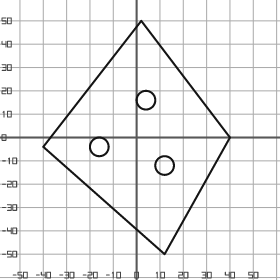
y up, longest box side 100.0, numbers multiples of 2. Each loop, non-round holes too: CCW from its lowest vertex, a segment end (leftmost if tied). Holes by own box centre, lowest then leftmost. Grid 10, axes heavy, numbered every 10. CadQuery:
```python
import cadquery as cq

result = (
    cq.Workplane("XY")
    .moveTo(12.0, -50.0)
    .lineTo(40.0, 0.0)
    .lineTo(2.0, 50.0)
    .lineTo(-40.0, -4.0)
    .close()
    .moveTo(12.0, -12.0)
    .circle(4.0)
    .moveTo(-16.0, -4.0)
    .circle(4.0)
    .moveTo(4.0, 16.0)
    .circle(4.0)
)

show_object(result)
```